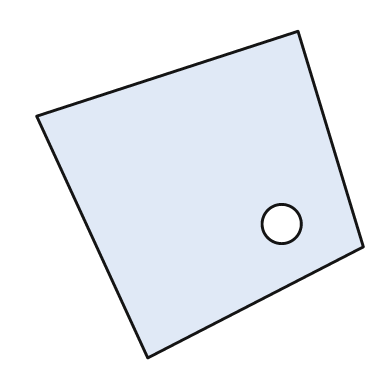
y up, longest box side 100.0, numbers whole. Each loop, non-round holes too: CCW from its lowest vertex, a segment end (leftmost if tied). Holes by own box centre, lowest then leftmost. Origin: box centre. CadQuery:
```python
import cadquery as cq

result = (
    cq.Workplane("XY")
    .moveTo(-16.0, -50.0)
    .lineTo(50.0, -16.0)
    .lineTo(30.0, 50.0)
    .lineTo(-50.0, 24.0)
    .close()
    .moveTo(25.0, -9.0)
    .circle(6.0)
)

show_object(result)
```